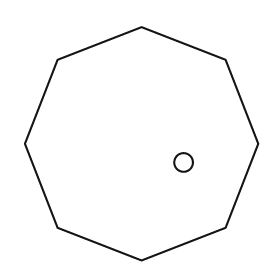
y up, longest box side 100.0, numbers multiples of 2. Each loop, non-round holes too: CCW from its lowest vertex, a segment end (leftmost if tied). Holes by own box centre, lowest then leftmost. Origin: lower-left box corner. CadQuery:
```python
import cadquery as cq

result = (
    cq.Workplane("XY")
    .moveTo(50.0, 0.0)
    .lineTo(86.0, 14.0)
    .lineTo(100.0, 50.0)
    .lineTo(86.0, 86.0)
    .lineTo(50.0, 100.0)
    .lineTo(14.0, 86.0)
    .lineTo(0.0, 50.0)
    .lineTo(14.0, 14.0)
    .close()
    .moveTo(68.0, 42.0)
    .circle(4.0)
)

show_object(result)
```